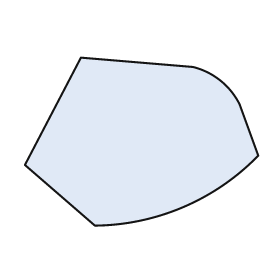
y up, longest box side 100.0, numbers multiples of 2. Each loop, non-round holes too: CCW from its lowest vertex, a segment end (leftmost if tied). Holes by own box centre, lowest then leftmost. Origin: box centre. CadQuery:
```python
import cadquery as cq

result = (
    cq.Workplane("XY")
    .moveTo(-20.0, -36.0)
    .threePointArc((18.0, -28.0), (50.0, -6.0))
    .lineTo(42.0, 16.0)
    .threePointArc((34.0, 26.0), (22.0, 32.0))
    .lineTo(-26.0, 36.0)
    .lineTo(-50.0, -10.0)
    .close()
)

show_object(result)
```